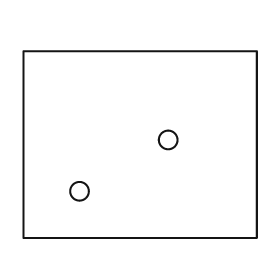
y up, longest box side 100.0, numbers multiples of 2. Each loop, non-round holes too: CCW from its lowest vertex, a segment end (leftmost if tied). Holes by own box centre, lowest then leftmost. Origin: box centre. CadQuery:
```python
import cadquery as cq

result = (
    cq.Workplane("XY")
    .moveTo(-50.0, -40.0)
    .lineTo(50.0, -40.0)
    .lineTo(50.0, 40.0)
    .lineTo(-50.0, 40.0)
    .close()
    .moveTo(-26.0, -20.0)
    .circle(4.0)
    .moveTo(12.0, 2.0)
    .circle(4.0)
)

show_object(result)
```